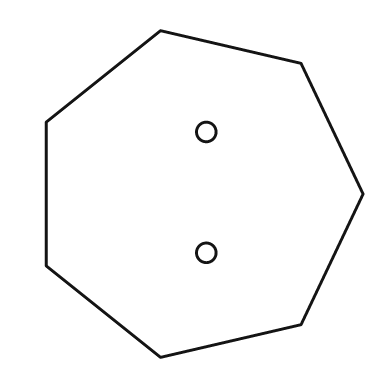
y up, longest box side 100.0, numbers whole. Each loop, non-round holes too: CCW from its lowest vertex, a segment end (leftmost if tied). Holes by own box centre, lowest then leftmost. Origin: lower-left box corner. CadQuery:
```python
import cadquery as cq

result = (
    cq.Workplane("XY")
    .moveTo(35.0, 0.0)
    .lineTo(78.0, 10.0)
    .lineTo(97.0, 50.0)
    .lineTo(78.0, 90.0)
    .lineTo(35.0, 100.0)
    .lineTo(0.0, 72.0)
    .lineTo(0.0, 28.0)
    .close()
    .moveTo(49.0, 32.0)
    .circle(3.0)
    .moveTo(49.0, 69.0)
    .circle(3.0)
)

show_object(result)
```